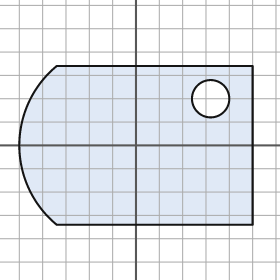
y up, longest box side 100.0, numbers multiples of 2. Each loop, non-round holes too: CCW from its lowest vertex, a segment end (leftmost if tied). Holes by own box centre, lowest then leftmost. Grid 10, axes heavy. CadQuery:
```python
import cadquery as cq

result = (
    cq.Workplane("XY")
    .moveTo(-34.0, -34.0)
    .lineTo(50.0, -34.0)
    .lineTo(50.0, 34.0)
    .lineTo(-34.0, 34.0)
    .threePointArc((-50.0, 0.0), (-34.0, -34.0))
    .close()
    .moveTo(32.0, 20.0)
    .circle(8.0)
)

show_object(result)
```